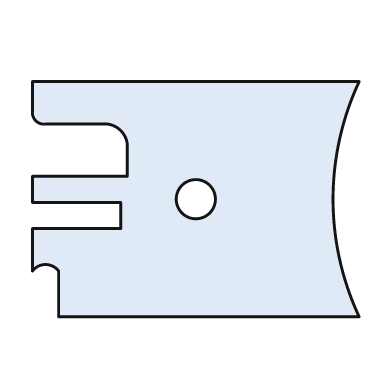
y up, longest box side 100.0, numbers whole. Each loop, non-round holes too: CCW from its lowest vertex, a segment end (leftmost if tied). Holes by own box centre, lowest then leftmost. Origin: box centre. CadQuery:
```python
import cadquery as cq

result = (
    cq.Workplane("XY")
    .moveTo(-42.0, -36.0)
    .lineTo(50.0, -36.0)
    .threePointArc((42.0, 0.0), (50.0, 36.0))
    .lineTo(-50.0, 36.0)
    .lineTo(-50.0, 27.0)
    .threePointArc((-49.0, 24.0), (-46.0, 23.0))
    .lineTo(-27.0, 23.0)
    .threePointArc((-23.0, 21.0), (-21.0, 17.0))
    .lineTo(-21.0, 7.0)
    .lineTo(-50.0, 7.0)
    .lineTo(-50.0, -1.0)
    .lineTo(-23.0, -1.0)
    .lineTo(-23.0, -9.0)
    .lineTo(-50.0, -9.0)
    .lineTo(-50.0, -22.0)
    .threePointArc((-46.0, -20.0), (-42.0, -22.0))
    .close()
    .moveTo(0.0, 0.0)
    .circle(6.0)
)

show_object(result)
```